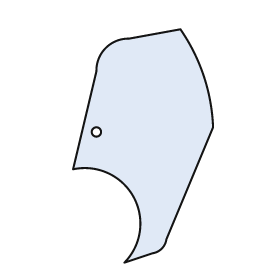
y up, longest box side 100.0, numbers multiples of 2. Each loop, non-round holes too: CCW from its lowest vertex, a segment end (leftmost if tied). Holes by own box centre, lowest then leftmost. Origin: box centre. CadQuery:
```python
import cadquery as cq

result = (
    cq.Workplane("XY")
    .moveTo(-8.0, -50.0)
    .lineTo(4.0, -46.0)
    .threePointArc((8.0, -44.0), (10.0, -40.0))
    .lineTo(30.0, 8.0)
    .threePointArc((26.0, 30.0), (16.0, 50.0))
    .lineTo(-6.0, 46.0)
    .threePointArc((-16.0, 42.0), (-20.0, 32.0))
    .lineTo(-30.0, -10.0)
    .threePointArc((-4.0, -22.0), (-8.0, -50.0))
    .close()
    .moveTo(-20.0, 6.0)
    .circle(2.0)
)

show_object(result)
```